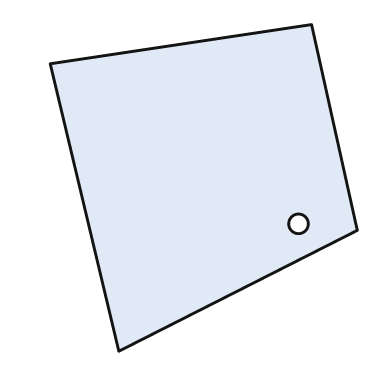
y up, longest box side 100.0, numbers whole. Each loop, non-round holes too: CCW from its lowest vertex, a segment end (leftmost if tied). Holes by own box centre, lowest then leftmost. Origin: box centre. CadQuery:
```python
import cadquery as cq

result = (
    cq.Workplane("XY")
    .moveTo(-26.0, -50.0)
    .lineTo(47.0, -13.0)
    .lineTo(33.0, 50.0)
    .lineTo(-47.0, 38.0)
    .close()
    .moveTo(29.0, -11.0)
    .circle(3.0)
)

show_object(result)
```